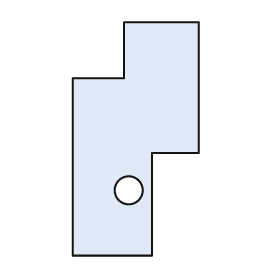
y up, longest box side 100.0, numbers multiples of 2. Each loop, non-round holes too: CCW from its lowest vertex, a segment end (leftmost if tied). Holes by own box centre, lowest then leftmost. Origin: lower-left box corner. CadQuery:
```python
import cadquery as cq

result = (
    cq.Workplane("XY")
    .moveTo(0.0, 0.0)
    .lineTo(34.0, 0.0)
    .lineTo(34.0, 44.0)
    .lineTo(54.0, 44.0)
    .lineTo(54.0, 100.0)
    .lineTo(22.0, 100.0)
    .lineTo(22.0, 76.0)
    .lineTo(0.0, 76.0)
    .close()
    .moveTo(24.0, 28.0)
    .circle(6.0)
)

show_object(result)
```